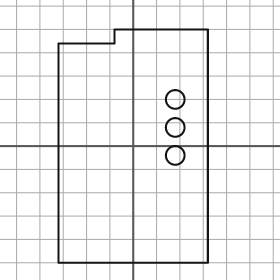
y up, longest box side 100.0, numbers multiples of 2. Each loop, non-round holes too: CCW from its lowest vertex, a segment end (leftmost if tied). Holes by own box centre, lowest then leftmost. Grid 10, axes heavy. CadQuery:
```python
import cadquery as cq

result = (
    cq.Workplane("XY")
    .moveTo(-32.0, -50.0)
    .lineTo(32.0, -50.0)
    .lineTo(32.0, 50.0)
    .lineTo(-8.0, 50.0)
    .lineTo(-8.0, 44.0)
    .lineTo(-32.0, 44.0)
    .close()
    .moveTo(18.0, -4.0)
    .circle(4.0)
    .moveTo(18.0, 8.0)
    .circle(4.0)
    .moveTo(18.0, 20.0)
    .circle(4.0)
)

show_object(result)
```